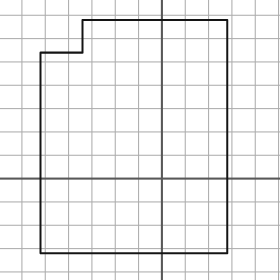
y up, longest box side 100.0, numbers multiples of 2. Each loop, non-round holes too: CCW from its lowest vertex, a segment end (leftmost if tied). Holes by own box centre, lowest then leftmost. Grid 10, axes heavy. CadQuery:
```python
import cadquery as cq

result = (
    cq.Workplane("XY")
    .moveTo(-52.0, -32.0)
    .lineTo(28.0, -32.0)
    .lineTo(28.0, 68.0)
    .lineTo(-34.0, 68.0)
    .lineTo(-34.0, 54.0)
    .lineTo(-52.0, 54.0)
    .close()
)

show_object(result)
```